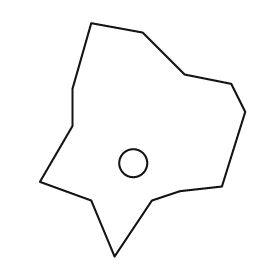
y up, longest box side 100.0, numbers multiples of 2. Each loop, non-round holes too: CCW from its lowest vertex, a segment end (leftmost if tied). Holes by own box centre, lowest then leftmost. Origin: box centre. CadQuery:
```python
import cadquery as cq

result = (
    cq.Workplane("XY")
    .moveTo(-12.0, -50.0)
    .lineTo(4.0, -26.0)
    .lineTo(16.0, -22.0)
    .lineTo(34.0, -20.0)
    .lineTo(44.0, 12.0)
    .lineTo(38.0, 24.0)
    .lineTo(18.0, 28.0)
    .lineTo(0.0, 46.0)
    .lineTo(-22.0, 50.0)
    .lineTo(-30.0, 22.0)
    .lineTo(-30.0, 6.0)
    .lineTo(-44.0, -18.0)
    .lineTo(-22.0, -26.0)
    .close()
    .moveTo(-4.0, -10.0)
    .circle(6.0)
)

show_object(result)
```